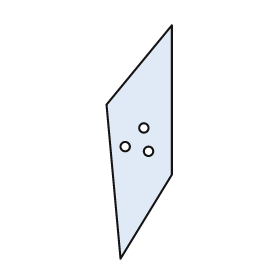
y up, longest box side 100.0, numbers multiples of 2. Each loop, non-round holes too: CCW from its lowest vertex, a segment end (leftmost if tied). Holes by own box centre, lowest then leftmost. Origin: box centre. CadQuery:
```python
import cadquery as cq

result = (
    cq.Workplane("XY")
    .moveTo(-8.0, -50.0)
    .lineTo(14.0, -14.0)
    .lineTo(14.0, 50.0)
    .lineTo(-14.0, 16.0)
    .close()
    .moveTo(4.0, -4.0)
    .circle(2.0)
    .moveTo(-6.0, -2.0)
    .circle(2.0)
    .moveTo(2.0, 6.0)
    .circle(2.0)
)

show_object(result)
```